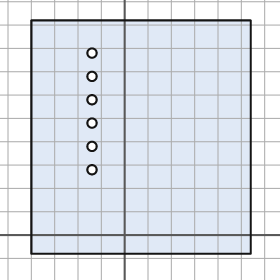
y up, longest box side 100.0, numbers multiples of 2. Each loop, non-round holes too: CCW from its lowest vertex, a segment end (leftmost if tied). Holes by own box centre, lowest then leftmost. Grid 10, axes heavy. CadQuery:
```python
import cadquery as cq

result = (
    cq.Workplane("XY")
    .moveTo(-40.0, -8.0)
    .lineTo(54.0, -8.0)
    .lineTo(54.0, 92.0)
    .lineTo(-40.0, 92.0)
    .close()
    .moveTo(-14.0, 28.0)
    .circle(2.0)
    .moveTo(-14.0, 38.0)
    .circle(2.0)
    .moveTo(-14.0, 48.0)
    .circle(2.0)
    .moveTo(-14.0, 58.0)
    .circle(2.0)
    .moveTo(-14.0, 68.0)
    .circle(2.0)
    .moveTo(-14.0, 78.0)
    .circle(2.0)
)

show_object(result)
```